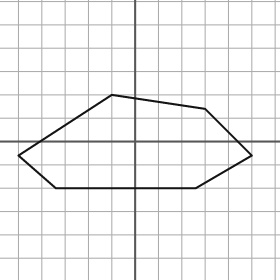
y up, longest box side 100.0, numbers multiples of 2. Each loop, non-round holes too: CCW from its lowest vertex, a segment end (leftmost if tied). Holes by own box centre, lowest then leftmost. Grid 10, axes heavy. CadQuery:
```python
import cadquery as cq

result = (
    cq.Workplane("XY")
    .moveTo(-34.0, -20.0)
    .lineTo(26.0, -20.0)
    .lineTo(50.0, -6.0)
    .lineTo(30.0, 14.0)
    .lineTo(-10.0, 20.0)
    .lineTo(-50.0, -6.0)
    .close()
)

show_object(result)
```